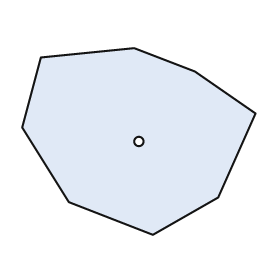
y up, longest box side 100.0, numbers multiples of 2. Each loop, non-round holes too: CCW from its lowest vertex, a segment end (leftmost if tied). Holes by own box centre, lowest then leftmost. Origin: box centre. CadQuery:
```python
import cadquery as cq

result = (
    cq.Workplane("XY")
    .moveTo(6.0, -40.0)
    .lineTo(34.0, -24.0)
    .lineTo(50.0, 12.0)
    .lineTo(24.0, 30.0)
    .lineTo(-2.0, 40.0)
    .lineTo(-42.0, 36.0)
    .lineTo(-50.0, 6.0)
    .lineTo(-30.0, -26.0)
    .close()
    .moveTo(0.0, 0.0)
    .circle(2.0)
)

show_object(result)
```